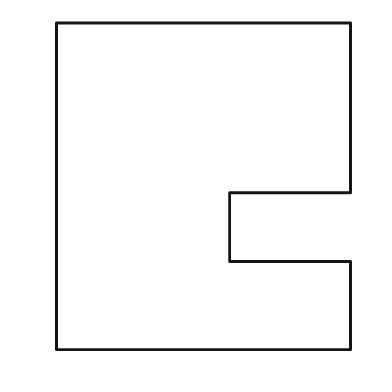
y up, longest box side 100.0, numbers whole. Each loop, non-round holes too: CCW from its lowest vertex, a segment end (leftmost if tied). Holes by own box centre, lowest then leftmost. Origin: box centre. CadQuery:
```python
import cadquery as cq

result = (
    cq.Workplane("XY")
    .moveTo(-45.0, -50.0)
    .lineTo(45.0, -50.0)
    .lineTo(45.0, -23.0)
    .lineTo(8.0, -23.0)
    .lineTo(8.0, -2.0)
    .lineTo(45.0, -2.0)
    .lineTo(45.0, 50.0)
    .lineTo(-45.0, 50.0)
    .close()
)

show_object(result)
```